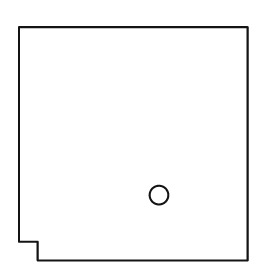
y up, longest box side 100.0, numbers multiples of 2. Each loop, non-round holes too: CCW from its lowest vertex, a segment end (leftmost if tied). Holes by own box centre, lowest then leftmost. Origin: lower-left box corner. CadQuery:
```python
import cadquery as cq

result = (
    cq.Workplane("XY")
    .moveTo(8.0, 0.0)
    .lineTo(98.0, 0.0)
    .lineTo(98.0, 100.0)
    .lineTo(0.0, 100.0)
    .lineTo(0.0, 8.0)
    .lineTo(8.0, 8.0)
    .close()
    .moveTo(60.0, 28.0)
    .circle(4.0)
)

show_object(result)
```